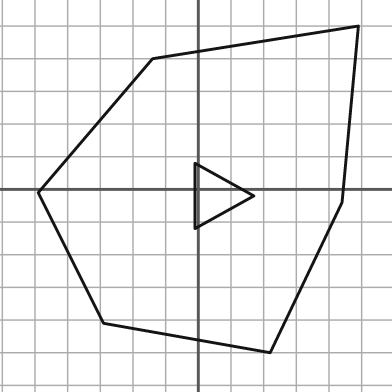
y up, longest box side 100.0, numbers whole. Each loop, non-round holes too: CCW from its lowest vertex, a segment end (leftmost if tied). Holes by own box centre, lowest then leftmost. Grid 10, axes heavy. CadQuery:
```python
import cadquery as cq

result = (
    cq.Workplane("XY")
    .moveTo(22.0, -50.0)
    .lineTo(44.0, -4.0)
    .lineTo(49.0, 50.0)
    .lineTo(-14.0, 40.0)
    .lineTo(-49.0, -1.0)
    .lineTo(-29.0, -41.0)
    .close()
    .moveTo(-1.0, -12.0)
    .lineTo(17.0, -2.0)
    .lineTo(-1.0, 8.0)
    .close()
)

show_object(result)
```